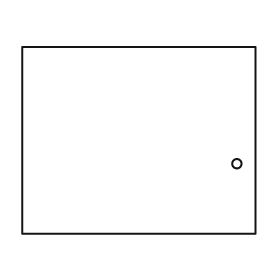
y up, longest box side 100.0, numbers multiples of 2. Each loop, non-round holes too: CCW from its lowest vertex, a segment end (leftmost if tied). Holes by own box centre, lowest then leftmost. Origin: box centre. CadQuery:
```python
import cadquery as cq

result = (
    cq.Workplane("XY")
    .moveTo(-50.0, -40.0)
    .lineTo(50.0, -40.0)
    .lineTo(50.0, 40.0)
    .lineTo(-50.0, 40.0)
    .close()
    .moveTo(42.0, -10.0)
    .circle(2.0)
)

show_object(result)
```